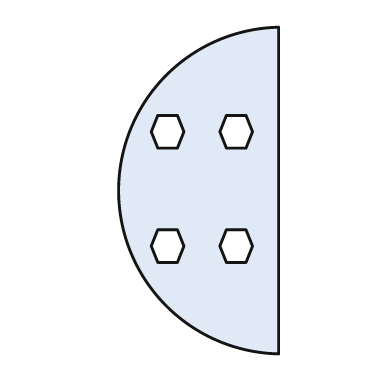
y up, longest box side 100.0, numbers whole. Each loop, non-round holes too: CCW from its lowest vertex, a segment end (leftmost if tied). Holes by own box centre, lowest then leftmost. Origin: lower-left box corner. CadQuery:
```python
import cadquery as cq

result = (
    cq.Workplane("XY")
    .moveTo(49.0, 0.0)
    .lineTo(49.0, 100.0)
    .threePointArc((0.0, 50.0), (49.0, 0.0))
    .close()
    .moveTo(12.0, 28.0)
    .lineTo(18.0, 28.0)
    .lineTo(20.0, 33.0)
    .lineTo(18.0, 38.0)
    .lineTo(12.0, 38.0)
    .lineTo(10.0, 33.0)
    .close()
    .moveTo(33.0, 28.0)
    .lineTo(39.0, 28.0)
    .lineTo(41.0, 33.0)
    .lineTo(39.0, 38.0)
    .lineTo(33.0, 38.0)
    .lineTo(31.0, 33.0)
    .close()
    .moveTo(12.0, 63.0)
    .lineTo(18.0, 63.0)
    .lineTo(20.0, 68.0)
    .lineTo(18.0, 73.0)
    .lineTo(12.0, 73.0)
    .lineTo(10.0, 68.0)
    .close()
    .moveTo(33.0, 63.0)
    .lineTo(39.0, 63.0)
    .lineTo(41.0, 68.0)
    .lineTo(39.0, 73.0)
    .lineTo(33.0, 73.0)
    .lineTo(31.0, 68.0)
    .close()
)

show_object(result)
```